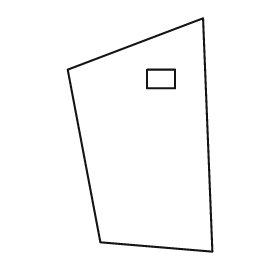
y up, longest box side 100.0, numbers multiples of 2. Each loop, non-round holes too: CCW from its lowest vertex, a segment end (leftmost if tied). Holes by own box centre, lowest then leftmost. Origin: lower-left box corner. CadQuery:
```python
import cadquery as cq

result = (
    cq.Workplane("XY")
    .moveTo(62.0, 0.0)
    .lineTo(58.0, 100.0)
    .lineTo(0.0, 78.0)
    .lineTo(14.0, 4.0)
    .close()
    .moveTo(34.0, 70.0)
    .lineTo(46.0, 70.0)
    .lineTo(46.0, 78.0)
    .lineTo(34.0, 78.0)
    .close()
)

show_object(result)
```